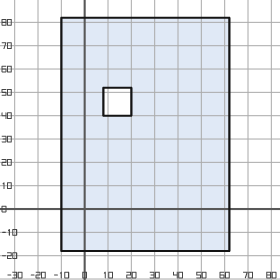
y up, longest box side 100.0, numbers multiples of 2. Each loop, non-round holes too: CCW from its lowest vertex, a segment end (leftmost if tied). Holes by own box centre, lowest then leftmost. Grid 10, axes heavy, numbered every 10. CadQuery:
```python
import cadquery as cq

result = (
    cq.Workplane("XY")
    .moveTo(-10.0, -18.0)
    .lineTo(62.0, -18.0)
    .lineTo(62.0, 82.0)
    .lineTo(-10.0, 82.0)
    .close()
    .moveTo(8.0, 40.0)
    .lineTo(20.0, 40.0)
    .lineTo(20.0, 52.0)
    .lineTo(8.0, 52.0)
    .close()
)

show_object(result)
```